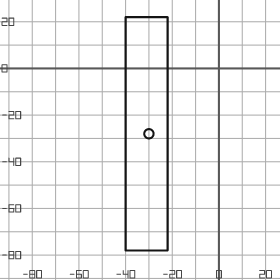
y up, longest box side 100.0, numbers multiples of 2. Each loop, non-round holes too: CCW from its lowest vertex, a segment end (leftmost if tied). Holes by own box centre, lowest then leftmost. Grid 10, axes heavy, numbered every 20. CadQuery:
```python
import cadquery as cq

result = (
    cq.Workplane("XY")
    .moveTo(-40.0, -78.0)
    .lineTo(-22.0, -78.0)
    .lineTo(-22.0, 22.0)
    .lineTo(-40.0, 22.0)
    .close()
    .moveTo(-30.0, -28.0)
    .circle(2.0)
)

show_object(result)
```